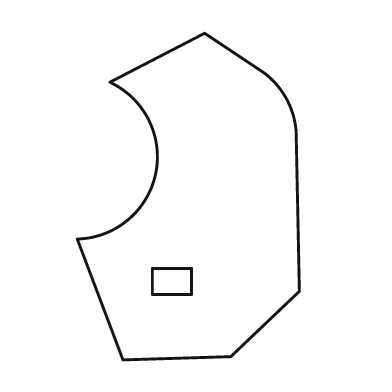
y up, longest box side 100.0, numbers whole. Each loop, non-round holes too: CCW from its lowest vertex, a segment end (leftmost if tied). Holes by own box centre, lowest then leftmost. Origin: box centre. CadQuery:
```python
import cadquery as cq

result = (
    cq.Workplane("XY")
    .moveTo(-20.0, -50.0)
    .lineTo(13.0, -49.0)
    .lineTo(34.0, -29.0)
    .lineTo(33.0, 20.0)
    .threePointArc((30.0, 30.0), (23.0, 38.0))
    .lineTo(5.0, 50.0)
    .lineTo(-24.0, 35.0)
    .threePointArc((-10.0, 7.0), (-34.0, -13.0))
    .close()
    .moveTo(-11.0, -30.0)
    .lineTo(1.0, -30.0)
    .lineTo(1.0, -22.0)
    .lineTo(-11.0, -22.0)
    .close()
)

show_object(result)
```